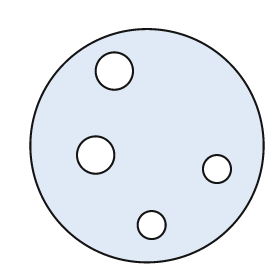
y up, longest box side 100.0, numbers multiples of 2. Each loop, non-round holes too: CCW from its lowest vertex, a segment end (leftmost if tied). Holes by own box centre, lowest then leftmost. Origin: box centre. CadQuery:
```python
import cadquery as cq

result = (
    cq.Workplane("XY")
    .moveTo(0.0, 0.0)
    .circle(50.0)
    .moveTo(2.0, -34.0)
    .circle(6.0)
    .moveTo(30.0, -10.0)
    .circle(6.0)
    .moveTo(-22.0, -4.0)
    .circle(8.0)
    .moveTo(-14.0, 32.0)
    .circle(8.0)
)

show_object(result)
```